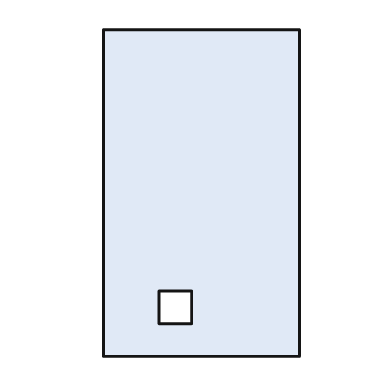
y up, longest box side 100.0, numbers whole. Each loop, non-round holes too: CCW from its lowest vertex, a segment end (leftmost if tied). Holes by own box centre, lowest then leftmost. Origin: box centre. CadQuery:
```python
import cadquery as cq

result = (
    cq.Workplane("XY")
    .moveTo(-30.0, -50.0)
    .lineTo(30.0, -50.0)
    .lineTo(30.0, 50.0)
    .lineTo(-30.0, 50.0)
    .close()
    .moveTo(-13.0, -40.0)
    .lineTo(-3.0, -40.0)
    .lineTo(-3.0, -30.0)
    .lineTo(-13.0, -30.0)
    .close()
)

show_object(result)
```